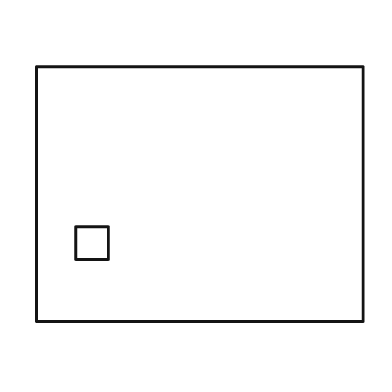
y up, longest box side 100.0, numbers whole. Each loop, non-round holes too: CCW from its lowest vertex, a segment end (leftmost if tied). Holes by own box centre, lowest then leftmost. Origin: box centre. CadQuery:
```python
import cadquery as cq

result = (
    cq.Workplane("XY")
    .moveTo(-50.0, -39.0)
    .lineTo(50.0, -39.0)
    .lineTo(50.0, 39.0)
    .lineTo(-50.0, 39.0)
    .close()
    .moveTo(-38.0, -20.0)
    .lineTo(-28.0, -20.0)
    .lineTo(-28.0, -10.0)
    .lineTo(-38.0, -10.0)
    .close()
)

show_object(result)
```